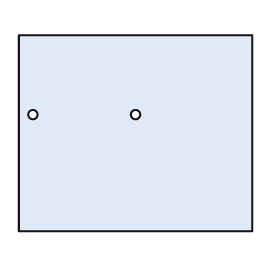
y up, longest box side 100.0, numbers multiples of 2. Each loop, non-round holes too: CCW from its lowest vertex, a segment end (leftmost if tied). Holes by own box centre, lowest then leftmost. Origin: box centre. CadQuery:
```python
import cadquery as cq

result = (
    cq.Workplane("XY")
    .moveTo(-50.0, -42.0)
    .lineTo(50.0, -42.0)
    .lineTo(50.0, 42.0)
    .lineTo(-50.0, 42.0)
    .close()
    .moveTo(-44.0, 8.0)
    .circle(2.0)
    .moveTo(0.0, 8.0)
    .circle(2.0)
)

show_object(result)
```